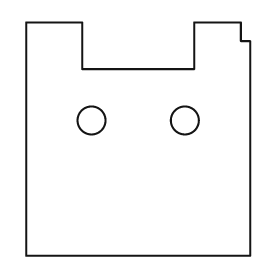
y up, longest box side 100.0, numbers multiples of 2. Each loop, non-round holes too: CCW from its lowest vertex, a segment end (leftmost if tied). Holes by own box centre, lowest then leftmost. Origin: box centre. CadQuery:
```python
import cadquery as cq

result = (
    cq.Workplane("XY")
    .moveTo(-48.0, -50.0)
    .lineTo(48.0, -50.0)
    .lineTo(48.0, 42.0)
    .lineTo(44.0, 42.0)
    .lineTo(44.0, 50.0)
    .lineTo(24.0, 50.0)
    .lineTo(24.0, 30.0)
    .lineTo(-24.0, 30.0)
    .lineTo(-24.0, 50.0)
    .lineTo(-48.0, 50.0)
    .close()
    .moveTo(-20.0, 8.0)
    .circle(6.0)
    .moveTo(20.0, 8.0)
    .circle(6.0)
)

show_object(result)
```